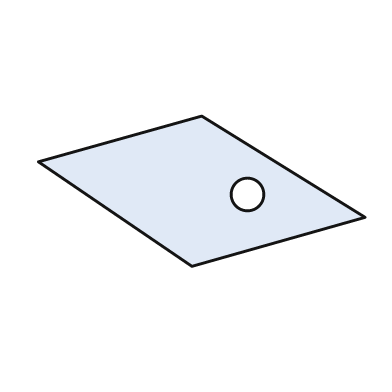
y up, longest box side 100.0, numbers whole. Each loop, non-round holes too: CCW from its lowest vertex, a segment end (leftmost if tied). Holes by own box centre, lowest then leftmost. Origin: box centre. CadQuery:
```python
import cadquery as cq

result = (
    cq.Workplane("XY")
    .moveTo(-3.0, -23.0)
    .lineTo(50.0, -8.0)
    .lineTo(0.0, 23.0)
    .lineTo(-50.0, 9.0)
    .close()
    .moveTo(14.0, -1.0)
    .circle(5.0)
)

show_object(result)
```